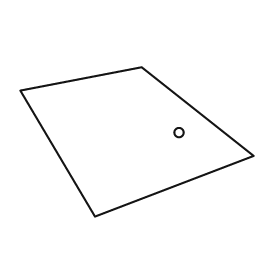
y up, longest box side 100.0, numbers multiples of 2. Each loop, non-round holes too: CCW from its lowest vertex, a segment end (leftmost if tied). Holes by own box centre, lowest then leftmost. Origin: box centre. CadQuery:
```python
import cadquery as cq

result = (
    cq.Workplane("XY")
    .moveTo(-18.0, -32.0)
    .lineTo(50.0, -6.0)
    .lineTo(2.0, 32.0)
    .lineTo(-50.0, 22.0)
    .close()
    .moveTo(18.0, 4.0)
    .circle(2.0)
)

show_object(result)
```